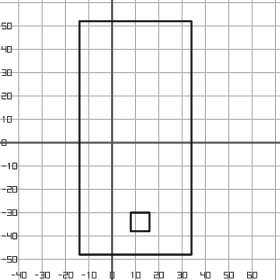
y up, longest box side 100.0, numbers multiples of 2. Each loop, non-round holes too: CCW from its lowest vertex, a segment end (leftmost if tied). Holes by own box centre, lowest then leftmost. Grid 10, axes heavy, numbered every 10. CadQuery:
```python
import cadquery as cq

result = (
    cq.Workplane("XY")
    .moveTo(-14.0, -48.0)
    .lineTo(34.0, -48.0)
    .lineTo(34.0, 52.0)
    .lineTo(-14.0, 52.0)
    .close()
    .moveTo(8.0, -38.0)
    .lineTo(16.0, -38.0)
    .lineTo(16.0, -30.0)
    .lineTo(8.0, -30.0)
    .close()
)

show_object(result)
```